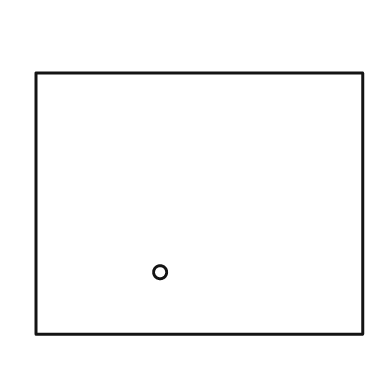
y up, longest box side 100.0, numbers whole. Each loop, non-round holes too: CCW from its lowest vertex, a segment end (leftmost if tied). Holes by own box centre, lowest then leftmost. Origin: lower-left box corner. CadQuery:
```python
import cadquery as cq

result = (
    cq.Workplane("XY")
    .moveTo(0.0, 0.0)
    .lineTo(100.0, 0.0)
    .lineTo(100.0, 80.0)
    .lineTo(0.0, 80.0)
    .close()
    .moveTo(38.0, 19.0)
    .circle(2.0)
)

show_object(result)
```